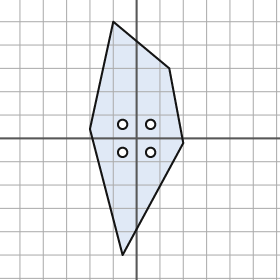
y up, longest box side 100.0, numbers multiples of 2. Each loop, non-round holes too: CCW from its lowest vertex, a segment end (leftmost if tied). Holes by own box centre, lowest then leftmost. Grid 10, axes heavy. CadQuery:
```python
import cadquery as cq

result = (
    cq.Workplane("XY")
    .moveTo(-6.0, -50.0)
    .lineTo(20.0, -2.0)
    .lineTo(14.0, 30.0)
    .lineTo(-10.0, 50.0)
    .lineTo(-20.0, 4.0)
    .close()
    .moveTo(-6.0, -6.0)
    .circle(2.0)
    .moveTo(6.0, -6.0)
    .circle(2.0)
    .moveTo(-6.0, 6.0)
    .circle(2.0)
    .moveTo(6.0, 6.0)
    .circle(2.0)
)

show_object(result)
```